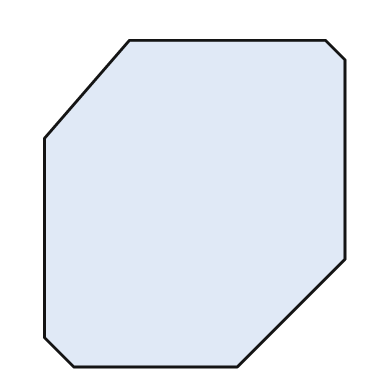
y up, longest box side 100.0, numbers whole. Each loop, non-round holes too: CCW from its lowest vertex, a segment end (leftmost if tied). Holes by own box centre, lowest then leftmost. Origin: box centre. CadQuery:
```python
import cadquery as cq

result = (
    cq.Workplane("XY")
    .moveTo(-37.0, -50.0)
    .lineTo(13.0, -50.0)
    .lineTo(46.0, -17.0)
    .lineTo(46.0, 44.0)
    .lineTo(40.0, 50.0)
    .lineTo(-20.0, 50.0)
    .lineTo(-46.0, 20.0)
    .lineTo(-46.0, -41.0)
    .close()
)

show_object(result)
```